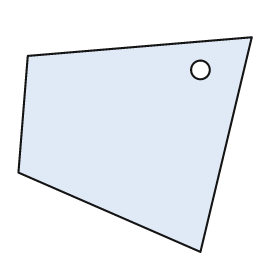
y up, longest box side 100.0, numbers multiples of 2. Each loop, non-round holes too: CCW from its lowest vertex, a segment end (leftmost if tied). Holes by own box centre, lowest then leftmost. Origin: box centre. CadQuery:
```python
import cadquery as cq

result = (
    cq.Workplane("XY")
    .moveTo(28.0, -46.0)
    .lineTo(50.0, 46.0)
    .lineTo(-46.0, 38.0)
    .lineTo(-50.0, -12.0)
    .close()
    .moveTo(28.0, 32.0)
    .circle(4.0)
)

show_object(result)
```